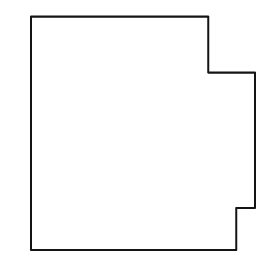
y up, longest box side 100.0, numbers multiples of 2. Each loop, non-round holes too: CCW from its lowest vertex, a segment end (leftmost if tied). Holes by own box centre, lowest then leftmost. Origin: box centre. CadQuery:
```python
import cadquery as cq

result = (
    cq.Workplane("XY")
    .moveTo(-48.0, -50.0)
    .lineTo(40.0, -50.0)
    .lineTo(40.0, -32.0)
    .lineTo(48.0, -32.0)
    .lineTo(48.0, 26.0)
    .lineTo(28.0, 26.0)
    .lineTo(28.0, 50.0)
    .lineTo(-48.0, 50.0)
    .close()
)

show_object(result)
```